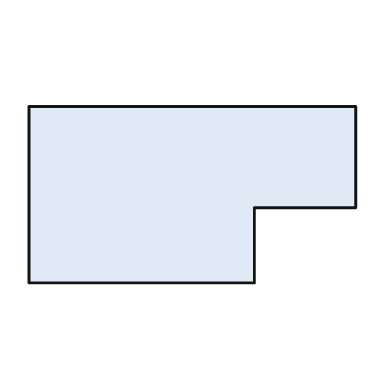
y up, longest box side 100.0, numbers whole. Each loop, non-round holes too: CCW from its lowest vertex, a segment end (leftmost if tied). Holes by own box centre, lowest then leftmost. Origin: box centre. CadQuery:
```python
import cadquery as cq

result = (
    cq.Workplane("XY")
    .moveTo(-50.0, -27.0)
    .lineTo(19.0, -27.0)
    .lineTo(19.0, -4.0)
    .lineTo(50.0, -4.0)
    .lineTo(50.0, 27.0)
    .lineTo(-50.0, 27.0)
    .close()
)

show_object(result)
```